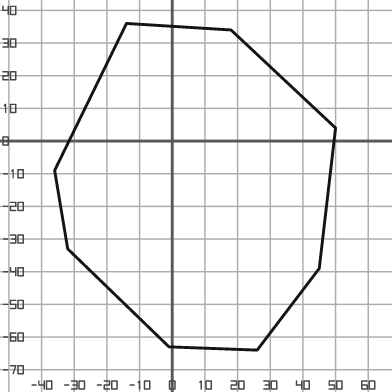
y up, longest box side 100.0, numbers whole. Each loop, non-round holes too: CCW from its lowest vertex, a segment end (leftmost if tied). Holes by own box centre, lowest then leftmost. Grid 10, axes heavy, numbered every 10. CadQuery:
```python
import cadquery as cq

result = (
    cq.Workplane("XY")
    .moveTo(26.0, -64.0)
    .lineTo(45.0, -39.0)
    .lineTo(50.0, 4.0)
    .lineTo(18.0, 34.0)
    .lineTo(-14.0, 36.0)
    .lineTo(-36.0, -9.0)
    .lineTo(-32.0, -33.0)
    .lineTo(-1.0, -63.0)
    .close()
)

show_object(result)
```